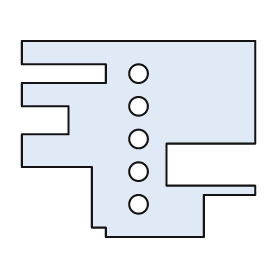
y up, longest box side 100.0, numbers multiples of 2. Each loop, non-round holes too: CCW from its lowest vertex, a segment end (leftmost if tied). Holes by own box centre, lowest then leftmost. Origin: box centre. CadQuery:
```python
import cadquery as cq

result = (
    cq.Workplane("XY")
    .moveTo(-14.0, -42.0)
    .lineTo(28.0, -42.0)
    .lineTo(28.0, -24.0)
    .lineTo(50.0, -24.0)
    .lineTo(50.0, -20.0)
    .lineTo(12.0, -20.0)
    .lineTo(12.0, -2.0)
    .lineTo(50.0, -2.0)
    .lineTo(50.0, 42.0)
    .lineTo(-50.0, 42.0)
    .lineTo(-50.0, 32.0)
    .lineTo(-14.0, 32.0)
    .lineTo(-14.0, 24.0)
    .lineTo(-50.0, 24.0)
    .lineTo(-50.0, 14.0)
    .lineTo(-30.0, 14.0)
    .lineTo(-30.0, 2.0)
    .lineTo(-50.0, 2.0)
    .lineTo(-50.0, -12.0)
    .lineTo(-20.0, -12.0)
    .lineTo(-20.0, -38.0)
    .lineTo(-14.0, -38.0)
    .close()
    .moveTo(0.0, -28.0)
    .circle(4.0)
    .moveTo(0.0, -14.0)
    .circle(4.0)
    .moveTo(0.0, 0.0)
    .circle(4.0)
    .moveTo(0.0, 14.0)
    .circle(4.0)
    .moveTo(0.0, 28.0)
    .circle(4.0)
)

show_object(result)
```